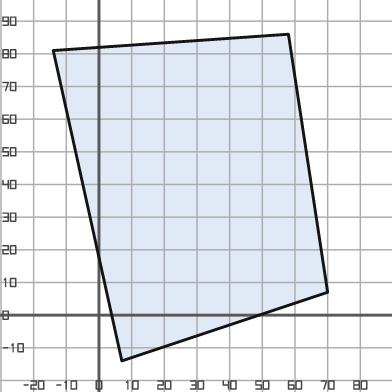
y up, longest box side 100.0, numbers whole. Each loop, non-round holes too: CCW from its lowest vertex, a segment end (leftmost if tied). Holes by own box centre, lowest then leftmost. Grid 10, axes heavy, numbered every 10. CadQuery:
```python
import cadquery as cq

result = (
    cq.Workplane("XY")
    .moveTo(7.0, -14.0)
    .lineTo(70.0, 7.0)
    .lineTo(58.0, 86.0)
    .lineTo(-14.0, 81.0)
    .close()
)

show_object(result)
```